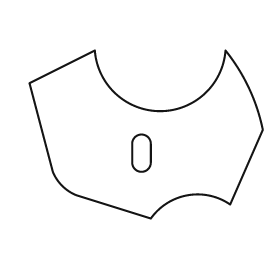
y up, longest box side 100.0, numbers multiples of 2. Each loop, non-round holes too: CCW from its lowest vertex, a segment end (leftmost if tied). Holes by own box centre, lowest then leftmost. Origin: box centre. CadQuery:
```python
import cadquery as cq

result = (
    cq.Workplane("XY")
    .moveTo(2.0, -36.0)
    .threePointArc((18.0, -26.0), (36.0, -30.0))
    .lineTo(50.0, 2.0)
    .threePointArc((44.0, 20.0), (34.0, 36.0))
    .threePointArc((6.0, 10.0), (-22.0, 36.0))
    .lineTo(-50.0, 22.0)
    .lineTo(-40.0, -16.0)
    .threePointArc((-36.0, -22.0), (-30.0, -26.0))
    .close()
    .moveTo(-6.0, -12.0)
    .threePointArc((-2.0, -16.0), (2.0, -12.0))
    .lineTo(2.0, -4.0)
    .threePointArc((-2.0, 0.0), (-6.0, -4.0))
    .close()
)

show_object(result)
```